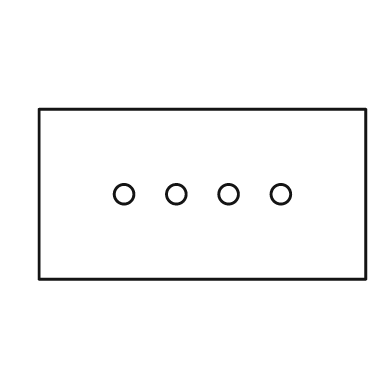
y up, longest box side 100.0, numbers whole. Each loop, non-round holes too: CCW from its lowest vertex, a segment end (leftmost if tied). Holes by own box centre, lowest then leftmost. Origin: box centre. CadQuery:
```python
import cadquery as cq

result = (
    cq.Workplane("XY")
    .moveTo(-50.0, -26.0)
    .lineTo(50.0, -26.0)
    .lineTo(50.0, 26.0)
    .lineTo(-50.0, 26.0)
    .close()
    .moveTo(-24.0, 0.0)
    .circle(3.0)
    .moveTo(-8.0, 0.0)
    .circle(3.0)
    .moveTo(8.0, 0.0)
    .circle(3.0)
    .moveTo(24.0, 0.0)
    .circle(3.0)
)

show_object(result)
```